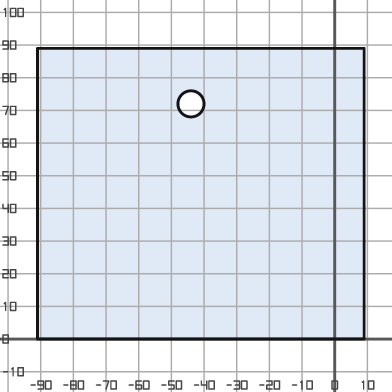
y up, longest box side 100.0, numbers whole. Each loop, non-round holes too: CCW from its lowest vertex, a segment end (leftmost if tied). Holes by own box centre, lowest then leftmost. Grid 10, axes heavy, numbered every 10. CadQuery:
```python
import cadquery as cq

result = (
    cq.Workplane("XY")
    .moveTo(-91.0, 0.0)
    .lineTo(9.0, 0.0)
    .lineTo(9.0, 89.0)
    .lineTo(-91.0, 89.0)
    .close()
    .moveTo(-44.0, 72.0)
    .circle(4.0)
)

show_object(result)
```